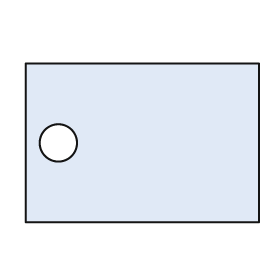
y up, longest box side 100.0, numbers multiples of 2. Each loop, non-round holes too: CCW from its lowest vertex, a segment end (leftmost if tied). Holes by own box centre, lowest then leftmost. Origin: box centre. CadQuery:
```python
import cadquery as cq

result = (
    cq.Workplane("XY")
    .moveTo(-50.0, -34.0)
    .lineTo(50.0, -34.0)
    .lineTo(50.0, 34.0)
    .lineTo(-50.0, 34.0)
    .close()
    .moveTo(-36.0, 0.0)
    .circle(8.0)
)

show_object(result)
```